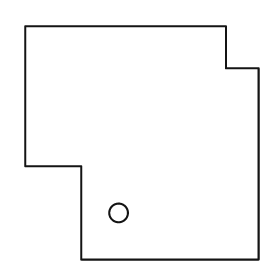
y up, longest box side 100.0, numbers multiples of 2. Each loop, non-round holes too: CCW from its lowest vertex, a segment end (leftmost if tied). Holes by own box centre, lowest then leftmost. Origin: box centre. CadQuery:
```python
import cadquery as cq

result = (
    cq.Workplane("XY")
    .moveTo(-26.0, -50.0)
    .lineTo(50.0, -50.0)
    .lineTo(50.0, 32.0)
    .lineTo(36.0, 32.0)
    .lineTo(36.0, 50.0)
    .lineTo(-50.0, 50.0)
    .lineTo(-50.0, -10.0)
    .lineTo(-26.0, -10.0)
    .close()
    .moveTo(-10.0, -30.0)
    .circle(4.0)
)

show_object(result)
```